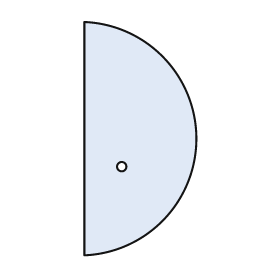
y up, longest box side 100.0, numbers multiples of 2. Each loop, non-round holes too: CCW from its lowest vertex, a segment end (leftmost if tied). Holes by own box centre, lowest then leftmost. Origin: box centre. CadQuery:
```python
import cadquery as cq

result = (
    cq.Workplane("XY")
    .moveTo(-24.0, -50.0)
    .threePointArc((24.0, 0.0), (-24.0, 50.0))
    .close()
    .moveTo(-8.0, -12.0)
    .circle(2.0)
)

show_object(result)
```